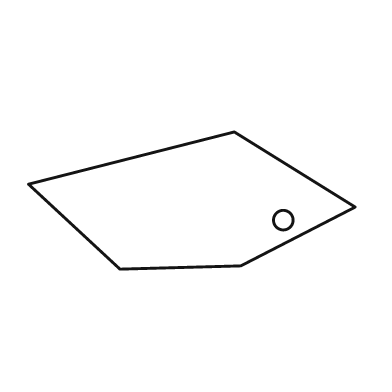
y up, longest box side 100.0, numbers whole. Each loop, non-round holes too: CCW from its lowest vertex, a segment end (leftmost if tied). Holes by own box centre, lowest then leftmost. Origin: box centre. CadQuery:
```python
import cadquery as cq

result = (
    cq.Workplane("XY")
    .moveTo(-22.0, -21.0)
    .lineTo(15.0, -20.0)
    .lineTo(50.0, -2.0)
    .lineTo(13.0, 21.0)
    .lineTo(-50.0, 5.0)
    .close()
    .moveTo(28.0, -6.0)
    .circle(3.0)
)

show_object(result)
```